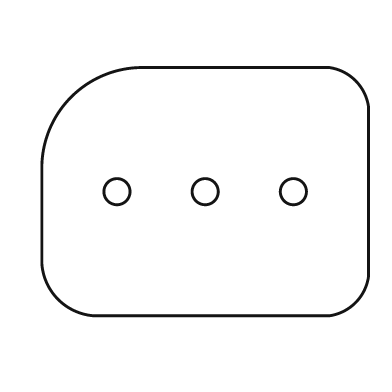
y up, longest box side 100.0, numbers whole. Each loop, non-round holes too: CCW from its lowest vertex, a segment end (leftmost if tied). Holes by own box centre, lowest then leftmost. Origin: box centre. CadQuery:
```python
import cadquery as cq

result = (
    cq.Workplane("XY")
    .moveTo(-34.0, -38.0)
    .lineTo(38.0, -38.0)
    .threePointArc((46.0, -34.0), (50.0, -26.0))
    .lineTo(50.0, 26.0)
    .threePointArc((46.0, 34.0), (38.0, 38.0))
    .lineTo(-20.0, 38.0)
    .threePointArc((-41.0, 29.0), (-50.0, 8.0))
    .lineTo(-50.0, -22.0)
    .threePointArc((-45.0, -33.0), (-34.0, -38.0))
    .close()
    .moveTo(-27.0, 0.0)
    .circle(4.0)
    .moveTo(0.0, 0.0)
    .circle(4.0)
    .moveTo(27.0, 0.0)
    .circle(4.0)
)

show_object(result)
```